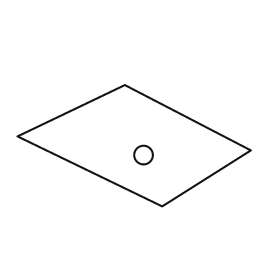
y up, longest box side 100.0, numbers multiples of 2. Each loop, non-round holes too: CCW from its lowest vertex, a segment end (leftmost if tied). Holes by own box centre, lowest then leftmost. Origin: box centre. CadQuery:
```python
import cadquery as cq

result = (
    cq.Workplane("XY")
    .moveTo(12.0, -26.0)
    .lineTo(50.0, -2.0)
    .lineTo(-4.0, 26.0)
    .lineTo(-50.0, 4.0)
    .close()
    .moveTo(4.0, -4.0)
    .circle(4.0)
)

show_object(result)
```